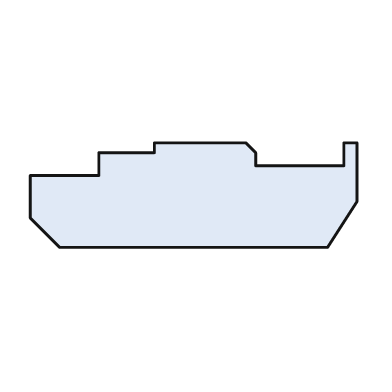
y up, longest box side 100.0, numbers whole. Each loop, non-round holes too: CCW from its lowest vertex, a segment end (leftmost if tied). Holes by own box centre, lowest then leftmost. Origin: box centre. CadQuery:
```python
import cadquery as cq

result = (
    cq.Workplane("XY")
    .moveTo(-41.0, -16.0)
    .lineTo(41.0, -16.0)
    .lineTo(50.0, -2.0)
    .lineTo(50.0, 16.0)
    .lineTo(46.0, 16.0)
    .lineTo(46.0, 9.0)
    .lineTo(19.0, 9.0)
    .lineTo(19.0, 13.0)
    .lineTo(16.0, 16.0)
    .lineTo(-12.0, 16.0)
    .lineTo(-12.0, 13.0)
    .lineTo(-29.0, 13.0)
    .lineTo(-29.0, 6.0)
    .lineTo(-50.0, 6.0)
    .lineTo(-50.0, -7.0)
    .close()
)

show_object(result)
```